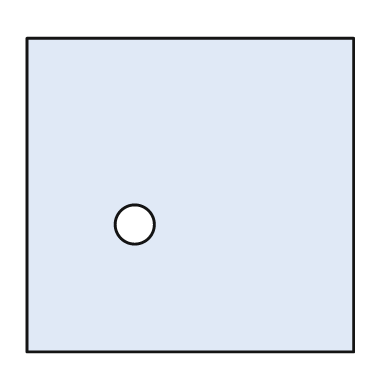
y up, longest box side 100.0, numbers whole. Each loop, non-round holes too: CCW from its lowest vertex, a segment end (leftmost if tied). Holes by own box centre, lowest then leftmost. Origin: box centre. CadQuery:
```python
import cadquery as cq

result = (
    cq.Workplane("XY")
    .moveTo(-50.0, -48.0)
    .lineTo(50.0, -48.0)
    .lineTo(50.0, 48.0)
    .lineTo(-50.0, 48.0)
    .close()
    .moveTo(-17.0, -9.0)
    .circle(6.0)
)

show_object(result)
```